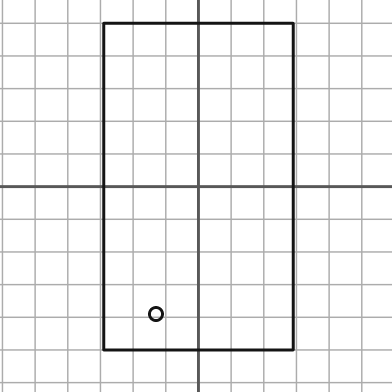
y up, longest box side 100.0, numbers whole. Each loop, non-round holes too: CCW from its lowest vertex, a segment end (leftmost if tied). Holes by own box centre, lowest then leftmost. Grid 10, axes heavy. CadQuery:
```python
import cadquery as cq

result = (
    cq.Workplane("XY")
    .moveTo(-29.0, -50.0)
    .lineTo(29.0, -50.0)
    .lineTo(29.0, 50.0)
    .lineTo(-29.0, 50.0)
    .close()
    .moveTo(-13.0, -39.0)
    .circle(2.0)
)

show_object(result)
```